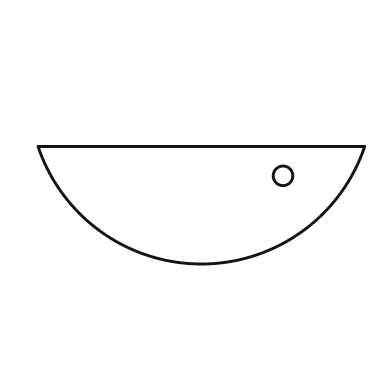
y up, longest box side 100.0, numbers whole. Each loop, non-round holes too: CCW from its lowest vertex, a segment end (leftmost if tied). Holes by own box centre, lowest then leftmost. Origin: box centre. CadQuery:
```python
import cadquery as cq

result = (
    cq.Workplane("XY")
    .moveTo(-50.0, 18.0)
    .threePointArc((0.0, -18.0), (50.0, 18.0))
    .close()
    .moveTo(25.0, 9.0)
    .circle(3.0)
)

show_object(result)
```